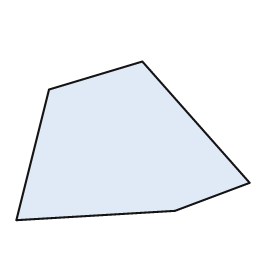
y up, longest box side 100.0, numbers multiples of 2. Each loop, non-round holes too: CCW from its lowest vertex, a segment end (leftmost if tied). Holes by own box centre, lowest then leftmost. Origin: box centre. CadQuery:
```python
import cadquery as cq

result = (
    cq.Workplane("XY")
    .moveTo(-50.0, -34.0)
    .lineTo(18.0, -30.0)
    .lineTo(50.0, -18.0)
    .lineTo(4.0, 34.0)
    .lineTo(-36.0, 22.0)
    .close()
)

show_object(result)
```